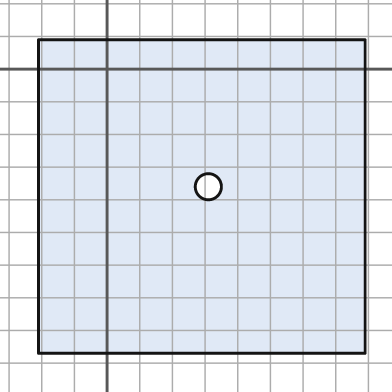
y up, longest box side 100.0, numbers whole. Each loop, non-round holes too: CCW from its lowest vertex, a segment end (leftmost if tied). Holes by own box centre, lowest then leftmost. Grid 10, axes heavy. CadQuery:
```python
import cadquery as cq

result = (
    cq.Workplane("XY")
    .moveTo(-21.0, -87.0)
    .lineTo(79.0, -87.0)
    .lineTo(79.0, 9.0)
    .lineTo(-21.0, 9.0)
    .close()
    .moveTo(31.0, -36.0)
    .circle(4.0)
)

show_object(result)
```